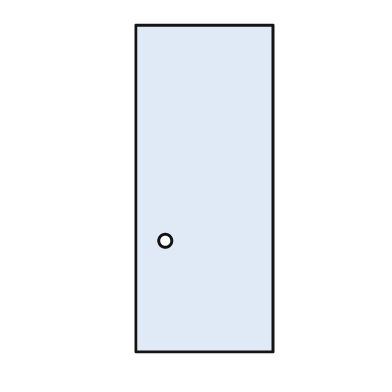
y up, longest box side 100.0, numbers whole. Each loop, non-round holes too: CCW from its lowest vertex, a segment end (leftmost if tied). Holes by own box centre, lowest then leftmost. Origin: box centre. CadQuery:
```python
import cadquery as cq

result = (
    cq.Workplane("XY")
    .moveTo(-21.0, -50.0)
    .lineTo(21.0, -50.0)
    .lineTo(21.0, 50.0)
    .lineTo(-21.0, 50.0)
    .close()
    .moveTo(-12.0, -16.0)
    .circle(2.0)
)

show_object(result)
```